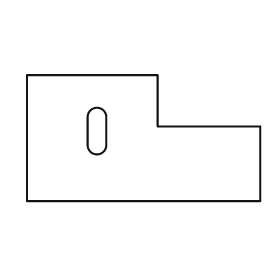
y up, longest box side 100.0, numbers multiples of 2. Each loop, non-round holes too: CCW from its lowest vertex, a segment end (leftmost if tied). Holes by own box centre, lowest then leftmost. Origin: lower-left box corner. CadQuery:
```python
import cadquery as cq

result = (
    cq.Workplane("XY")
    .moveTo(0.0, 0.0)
    .lineTo(100.0, 0.0)
    .lineTo(100.0, 32.0)
    .lineTo(56.0, 32.0)
    .lineTo(56.0, 54.0)
    .lineTo(0.0, 54.0)
    .close()
    .moveTo(26.0, 24.0)
    .threePointArc((30.0, 20.0), (34.0, 24.0))
    .lineTo(34.0, 36.0)
    .threePointArc((30.0, 40.0), (26.0, 36.0))
    .close()
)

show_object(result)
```